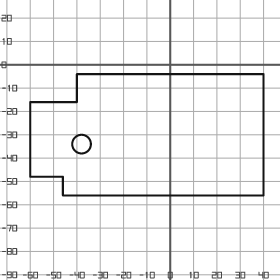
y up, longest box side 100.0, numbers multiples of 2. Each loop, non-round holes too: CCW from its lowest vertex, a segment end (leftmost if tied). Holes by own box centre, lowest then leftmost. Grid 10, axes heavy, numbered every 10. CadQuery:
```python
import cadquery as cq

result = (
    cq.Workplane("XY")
    .moveTo(-46.0, -56.0)
    .lineTo(40.0, -56.0)
    .lineTo(40.0, -4.0)
    .lineTo(-40.0, -4.0)
    .lineTo(-40.0, -16.0)
    .lineTo(-60.0, -16.0)
    .lineTo(-60.0, -48.0)
    .lineTo(-46.0, -48.0)
    .close()
    .moveTo(-38.0, -34.0)
    .circle(4.0)
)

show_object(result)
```